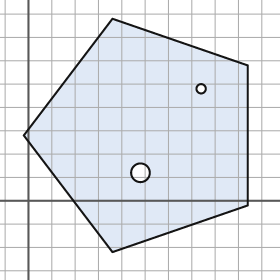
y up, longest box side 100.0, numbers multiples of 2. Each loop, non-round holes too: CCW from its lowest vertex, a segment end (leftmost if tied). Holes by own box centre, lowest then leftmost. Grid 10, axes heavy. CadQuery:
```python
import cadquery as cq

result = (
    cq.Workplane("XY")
    .moveTo(36.0, -22.0)
    .lineTo(94.0, -2.0)
    .lineTo(94.0, 58.0)
    .lineTo(36.0, 78.0)
    .lineTo(-2.0, 28.0)
    .close()
    .moveTo(48.0, 12.0)
    .circle(4.0)
    .moveTo(74.0, 48.0)
    .circle(2.0)
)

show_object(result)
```